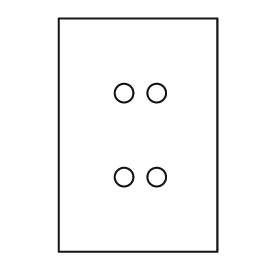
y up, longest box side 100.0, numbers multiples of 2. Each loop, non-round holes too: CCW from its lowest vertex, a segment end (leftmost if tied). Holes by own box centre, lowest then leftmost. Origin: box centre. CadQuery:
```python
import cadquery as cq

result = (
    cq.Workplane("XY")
    .moveTo(-34.0, -50.0)
    .lineTo(34.0, -50.0)
    .lineTo(34.0, 50.0)
    .lineTo(-34.0, 50.0)
    .close()
    .moveTo(-6.0, -18.0)
    .circle(4.0)
    .moveTo(8.0, -18.0)
    .circle(4.0)
    .moveTo(-6.0, 18.0)
    .circle(4.0)
    .moveTo(8.0, 18.0)
    .circle(4.0)
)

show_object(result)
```